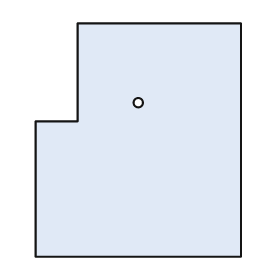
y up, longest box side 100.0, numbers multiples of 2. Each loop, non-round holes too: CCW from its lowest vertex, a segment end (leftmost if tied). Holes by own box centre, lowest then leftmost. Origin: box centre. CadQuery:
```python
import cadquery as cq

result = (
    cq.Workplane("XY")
    .moveTo(-44.0, -50.0)
    .lineTo(44.0, -50.0)
    .lineTo(44.0, 50.0)
    .lineTo(-26.0, 50.0)
    .lineTo(-26.0, 8.0)
    .lineTo(-44.0, 8.0)
    .close()
    .moveTo(0.0, 16.0)
    .circle(2.0)
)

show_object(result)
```